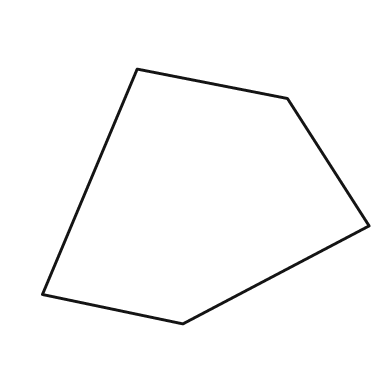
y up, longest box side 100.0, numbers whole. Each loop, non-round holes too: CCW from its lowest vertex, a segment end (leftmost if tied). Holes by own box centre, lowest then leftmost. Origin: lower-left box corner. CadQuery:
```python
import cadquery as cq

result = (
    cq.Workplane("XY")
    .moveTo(43.0, 0.0)
    .lineTo(100.0, 30.0)
    .lineTo(75.0, 69.0)
    .lineTo(29.0, 78.0)
    .lineTo(0.0, 9.0)
    .close()
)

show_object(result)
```